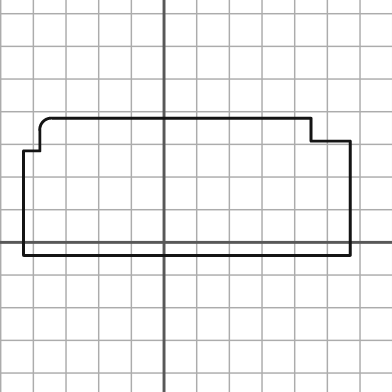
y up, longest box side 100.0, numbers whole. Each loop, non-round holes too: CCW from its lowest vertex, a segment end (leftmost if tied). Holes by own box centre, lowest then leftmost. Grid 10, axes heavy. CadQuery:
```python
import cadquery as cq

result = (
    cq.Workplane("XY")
    .moveTo(-43.0, -4.0)
    .lineTo(57.0, -4.0)
    .lineTo(57.0, 31.0)
    .lineTo(45.0, 31.0)
    .lineTo(45.0, 38.0)
    .lineTo(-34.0, 38.0)
    .threePointArc((-37.0, 37.0), (-38.0, 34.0))
    .lineTo(-38.0, 28.0)
    .lineTo(-43.0, 28.0)
    .close()
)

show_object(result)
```